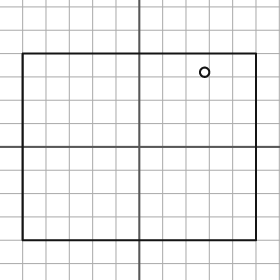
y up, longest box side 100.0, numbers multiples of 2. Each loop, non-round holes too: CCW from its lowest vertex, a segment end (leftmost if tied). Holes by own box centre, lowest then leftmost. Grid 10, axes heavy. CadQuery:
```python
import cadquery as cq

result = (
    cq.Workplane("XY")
    .moveTo(-50.0, -40.0)
    .lineTo(50.0, -40.0)
    .lineTo(50.0, 40.0)
    .lineTo(-50.0, 40.0)
    .close()
    .moveTo(28.0, 32.0)
    .circle(2.0)
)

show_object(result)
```